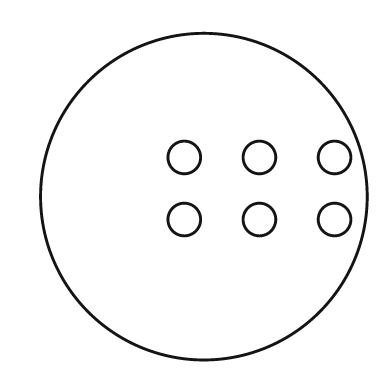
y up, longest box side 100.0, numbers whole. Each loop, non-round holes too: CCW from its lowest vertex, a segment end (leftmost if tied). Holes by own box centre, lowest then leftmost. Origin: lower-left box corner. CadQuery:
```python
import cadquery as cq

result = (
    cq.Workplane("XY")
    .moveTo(50.0, 50.0)
    .circle(50.0)
    .moveTo(44.0, 43.0)
    .circle(5.0)
    .moveTo(67.0, 43.0)
    .circle(5.0)
    .moveTo(90.0, 43.0)
    .circle(5.0)
    .moveTo(44.0, 62.0)
    .circle(5.0)
    .moveTo(67.0, 62.0)
    .circle(5.0)
    .moveTo(90.0, 62.0)
    .circle(5.0)
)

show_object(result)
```